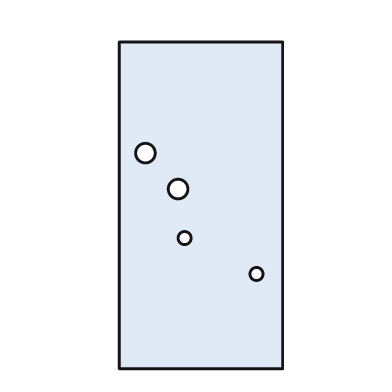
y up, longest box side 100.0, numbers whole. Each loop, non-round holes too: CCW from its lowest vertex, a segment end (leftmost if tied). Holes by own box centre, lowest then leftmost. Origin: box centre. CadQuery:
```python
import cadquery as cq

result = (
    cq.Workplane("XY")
    .moveTo(-25.0, -50.0)
    .lineTo(25.0, -50.0)
    .lineTo(25.0, 50.0)
    .lineTo(-25.0, 50.0)
    .close()
    .moveTo(17.0, -21.0)
    .circle(2.0)
    .moveTo(-5.0, -10.0)
    .circle(2.0)
    .moveTo(-7.0, 5.0)
    .circle(3.0)
    .moveTo(-17.0, 16.0)
    .circle(3.0)
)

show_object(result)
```